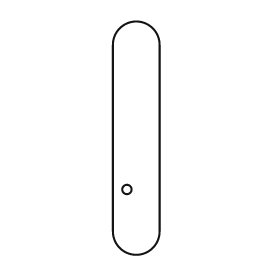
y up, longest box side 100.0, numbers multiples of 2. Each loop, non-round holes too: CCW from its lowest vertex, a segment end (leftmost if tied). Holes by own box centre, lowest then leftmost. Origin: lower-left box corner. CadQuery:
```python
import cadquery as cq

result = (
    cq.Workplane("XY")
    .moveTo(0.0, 10.0)
    .threePointArc((10.0, 0.0), (20.0, 10.0))
    .lineTo(20.0, 90.0)
    .threePointArc((10.0, 100.0), (0.0, 90.0))
    .close()
    .moveTo(6.0, 28.0)
    .circle(2.0)
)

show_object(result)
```